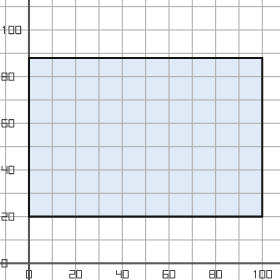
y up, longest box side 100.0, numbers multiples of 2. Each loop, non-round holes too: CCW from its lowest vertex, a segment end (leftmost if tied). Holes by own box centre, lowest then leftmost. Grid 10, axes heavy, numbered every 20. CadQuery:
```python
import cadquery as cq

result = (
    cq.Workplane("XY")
    .moveTo(0.0, 20.0)
    .lineTo(100.0, 20.0)
    .lineTo(100.0, 88.0)
    .lineTo(0.0, 88.0)
    .close()
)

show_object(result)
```